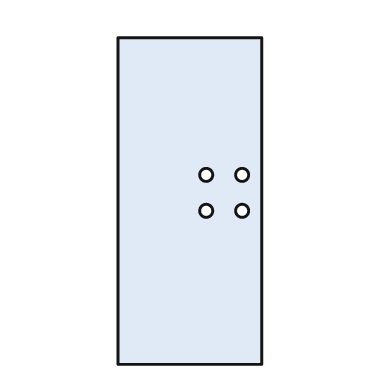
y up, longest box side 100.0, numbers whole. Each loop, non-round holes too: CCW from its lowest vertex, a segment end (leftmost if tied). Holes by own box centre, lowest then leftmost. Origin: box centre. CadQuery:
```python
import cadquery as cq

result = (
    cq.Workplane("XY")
    .moveTo(-22.0, -50.0)
    .lineTo(22.0, -50.0)
    .lineTo(22.0, 50.0)
    .lineTo(-22.0, 50.0)
    .close()
    .moveTo(5.0, -3.0)
    .circle(2.0)
    .moveTo(16.0, -3.0)
    .circle(2.0)
    .moveTo(5.0, 8.0)
    .circle(2.0)
    .moveTo(16.0, 8.0)
    .circle(2.0)
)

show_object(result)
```